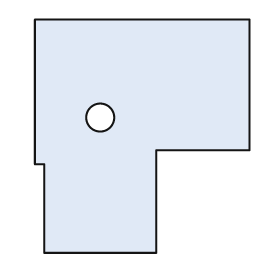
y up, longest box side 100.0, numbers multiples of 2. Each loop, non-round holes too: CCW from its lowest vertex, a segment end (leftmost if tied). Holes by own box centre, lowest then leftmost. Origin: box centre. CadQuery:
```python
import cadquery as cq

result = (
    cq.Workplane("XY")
    .moveTo(-42.0, -50.0)
    .lineTo(6.0, -50.0)
    .lineTo(6.0, -6.0)
    .lineTo(46.0, -6.0)
    .lineTo(46.0, 50.0)
    .lineTo(-46.0, 50.0)
    .lineTo(-46.0, -12.0)
    .lineTo(-42.0, -12.0)
    .close()
    .moveTo(-18.0, 8.0)
    .circle(6.0)
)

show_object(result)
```